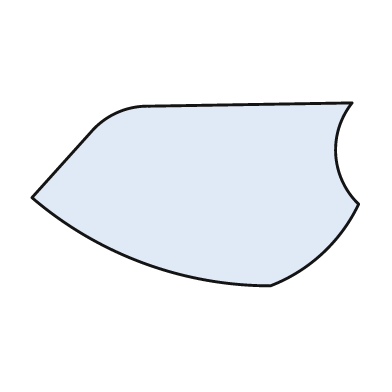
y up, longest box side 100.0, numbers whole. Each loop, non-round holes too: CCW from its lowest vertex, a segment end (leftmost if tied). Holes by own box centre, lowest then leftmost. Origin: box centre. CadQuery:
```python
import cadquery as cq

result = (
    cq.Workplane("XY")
    .moveTo(23.0, -28.0)
    .threePointArc((39.0, -18.0), (50.0, -3.0))
    .threePointArc((43.0, 12.0), (48.0, 28.0))
    .lineTo(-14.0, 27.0)
    .threePointArc((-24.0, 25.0), (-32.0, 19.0))
    .lineTo(-50.0, -1.0)
    .threePointArc((-16.0, -21.0), (23.0, -28.0))
    .close()
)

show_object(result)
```